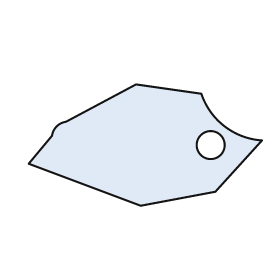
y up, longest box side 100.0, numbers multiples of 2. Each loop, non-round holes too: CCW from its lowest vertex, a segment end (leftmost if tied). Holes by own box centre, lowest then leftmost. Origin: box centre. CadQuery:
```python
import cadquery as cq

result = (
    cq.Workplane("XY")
    .moveTo(-2.0, -26.0)
    .lineTo(30.0, -20.0)
    .lineTo(50.0, 2.0)
    .threePointArc((34.0, 8.0), (24.0, 22.0))
    .lineTo(-4.0, 26.0)
    .lineTo(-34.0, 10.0)
    .threePointArc((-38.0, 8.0), (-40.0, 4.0))
    .lineTo(-50.0, -8.0)
    .close()
    .moveTo(28.0, 0.0)
    .circle(6.0)
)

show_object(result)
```